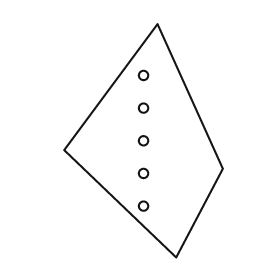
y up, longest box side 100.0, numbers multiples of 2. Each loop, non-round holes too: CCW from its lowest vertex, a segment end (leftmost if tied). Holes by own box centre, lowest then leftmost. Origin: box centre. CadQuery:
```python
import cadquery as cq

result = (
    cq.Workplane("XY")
    .moveTo(14.0, -50.0)
    .lineTo(34.0, -12.0)
    .lineTo(6.0, 50.0)
    .lineTo(-34.0, -4.0)
    .close()
    .moveTo(0.0, -28.0)
    .circle(2.0)
    .moveTo(0.0, -14.0)
    .circle(2.0)
    .moveTo(0.0, 0.0)
    .circle(2.0)
    .moveTo(0.0, 14.0)
    .circle(2.0)
    .moveTo(0.0, 28.0)
    .circle(2.0)
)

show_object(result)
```